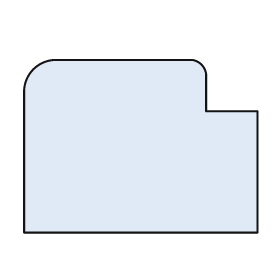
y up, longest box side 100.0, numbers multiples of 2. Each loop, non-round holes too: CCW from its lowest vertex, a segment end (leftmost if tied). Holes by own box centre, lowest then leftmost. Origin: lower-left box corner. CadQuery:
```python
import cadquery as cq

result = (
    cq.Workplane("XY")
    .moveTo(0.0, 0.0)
    .lineTo(100.0, 0.0)
    .lineTo(100.0, 52.0)
    .lineTo(78.0, 52.0)
    .lineTo(78.0, 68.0)
    .threePointArc((76.0, 72.0), (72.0, 74.0))
    .lineTo(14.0, 74.0)
    .threePointArc((4.0, 70.0), (0.0, 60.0))
    .close()
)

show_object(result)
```